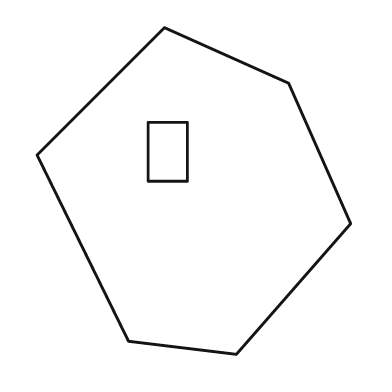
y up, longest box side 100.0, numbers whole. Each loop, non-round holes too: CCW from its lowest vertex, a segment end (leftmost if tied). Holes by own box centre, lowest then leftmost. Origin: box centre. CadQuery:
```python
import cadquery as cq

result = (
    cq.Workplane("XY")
    .moveTo(13.0, -50.0)
    .lineTo(48.0, -10.0)
    .lineTo(29.0, 33.0)
    .lineTo(-9.0, 50.0)
    .lineTo(-48.0, 11.0)
    .lineTo(-20.0, -46.0)
    .close()
    .moveTo(-14.0, 3.0)
    .lineTo(-2.0, 3.0)
    .lineTo(-2.0, 21.0)
    .lineTo(-14.0, 21.0)
    .close()
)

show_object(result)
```